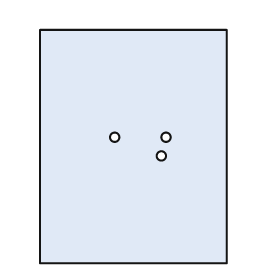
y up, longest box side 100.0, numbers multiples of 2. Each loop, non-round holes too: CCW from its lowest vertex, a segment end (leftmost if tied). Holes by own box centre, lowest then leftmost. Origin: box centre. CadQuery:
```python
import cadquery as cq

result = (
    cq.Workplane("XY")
    .moveTo(-40.0, -50.0)
    .lineTo(40.0, -50.0)
    .lineTo(40.0, 50.0)
    .lineTo(-40.0, 50.0)
    .close()
    .moveTo(12.0, -4.0)
    .circle(2.0)
    .moveTo(-8.0, 4.0)
    .circle(2.0)
    .moveTo(14.0, 4.0)
    .circle(2.0)
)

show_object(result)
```